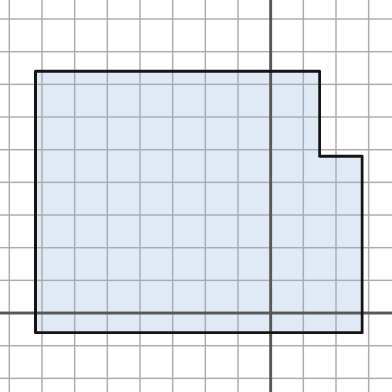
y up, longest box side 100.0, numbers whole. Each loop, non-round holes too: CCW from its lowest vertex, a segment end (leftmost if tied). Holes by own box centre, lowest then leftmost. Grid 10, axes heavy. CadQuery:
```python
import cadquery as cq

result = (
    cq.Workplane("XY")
    .moveTo(-72.0, -6.0)
    .lineTo(28.0, -6.0)
    .lineTo(28.0, 48.0)
    .lineTo(15.0, 48.0)
    .lineTo(15.0, 74.0)
    .lineTo(-72.0, 74.0)
    .close()
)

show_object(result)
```